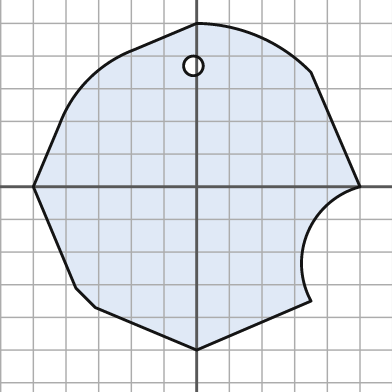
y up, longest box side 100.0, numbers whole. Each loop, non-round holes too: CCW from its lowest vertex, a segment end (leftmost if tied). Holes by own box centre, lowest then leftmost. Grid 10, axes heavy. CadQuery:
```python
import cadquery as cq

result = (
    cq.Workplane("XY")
    .moveTo(0.0, -50.0)
    .lineTo(35.0, -35.0)
    .threePointArc((34.0, -14.0), (50.0, 0.0))
    .lineTo(35.0, 35.0)
    .threePointArc((19.0, 46.0), (0.0, 50.0))
    .lineTo(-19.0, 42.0)
    .threePointArc((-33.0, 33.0), (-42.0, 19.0))
    .lineTo(-50.0, 0.0)
    .lineTo(-37.0, -31.0)
    .lineTo(-31.0, -37.0)
    .close()
    .moveTo(-1.0, 37.0)
    .circle(3.0)
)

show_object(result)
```